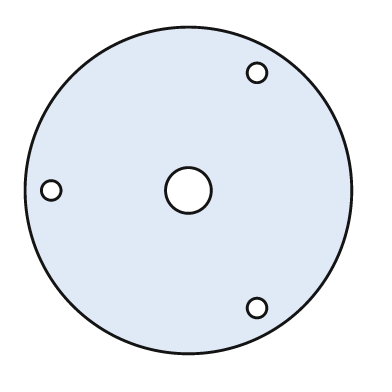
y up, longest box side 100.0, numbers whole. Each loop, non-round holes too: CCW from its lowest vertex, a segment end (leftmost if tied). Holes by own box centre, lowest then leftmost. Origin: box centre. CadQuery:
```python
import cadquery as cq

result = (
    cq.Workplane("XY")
    .moveTo(0.0, 0.0)
    .circle(50.0)
    .moveTo(21.0, -36.0)
    .circle(3.0)
    .moveTo(-42.0, 0.0)
    .circle(3.0)
    .moveTo(0.0, 0.0)
    .circle(7.0)
    .moveTo(21.0, 36.0)
    .circle(3.0)
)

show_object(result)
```